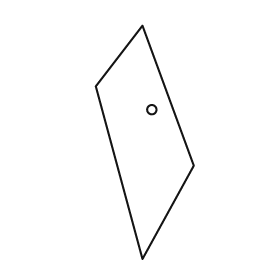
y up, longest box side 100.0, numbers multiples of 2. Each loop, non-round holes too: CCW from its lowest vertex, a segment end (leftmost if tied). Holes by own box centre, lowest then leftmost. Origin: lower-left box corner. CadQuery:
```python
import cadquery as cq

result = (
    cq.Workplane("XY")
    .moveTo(20.0, 0.0)
    .lineTo(42.0, 40.0)
    .lineTo(20.0, 100.0)
    .lineTo(0.0, 74.0)
    .close()
    .moveTo(24.0, 64.0)
    .circle(2.0)
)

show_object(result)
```